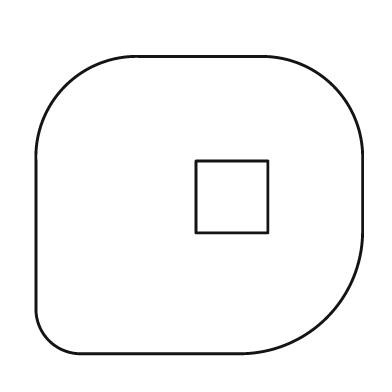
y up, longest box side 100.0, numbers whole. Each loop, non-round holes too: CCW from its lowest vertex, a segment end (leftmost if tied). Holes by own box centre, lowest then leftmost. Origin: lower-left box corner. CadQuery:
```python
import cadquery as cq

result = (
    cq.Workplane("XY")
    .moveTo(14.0, 0.0)
    .lineTo(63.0, 0.0)
    .threePointArc((89.0, 11.0), (100.0, 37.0))
    .lineTo(100.0, 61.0)
    .threePointArc((91.0, 82.0), (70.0, 91.0))
    .lineTo(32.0, 91.0)
    .threePointArc((9.0, 82.0), (0.0, 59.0))
    .lineTo(0.0, 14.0)
    .threePointArc((4.0, 4.0), (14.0, 0.0))
    .close()
    .moveTo(49.0, 37.0)
    .lineTo(71.0, 37.0)
    .lineTo(71.0, 59.0)
    .lineTo(49.0, 59.0)
    .close()
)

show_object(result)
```